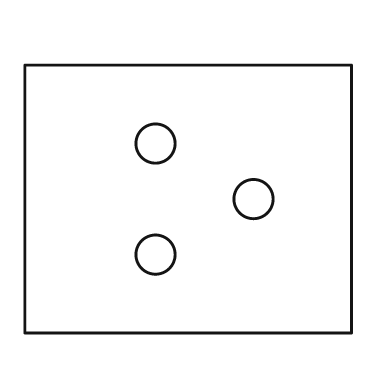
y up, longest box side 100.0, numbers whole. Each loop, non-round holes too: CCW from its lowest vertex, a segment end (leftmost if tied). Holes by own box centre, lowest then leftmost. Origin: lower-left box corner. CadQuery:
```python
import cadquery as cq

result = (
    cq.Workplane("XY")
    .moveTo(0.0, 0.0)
    .lineTo(100.0, 0.0)
    .lineTo(100.0, 82.0)
    .lineTo(0.0, 82.0)
    .close()
    .moveTo(40.0, 24.0)
    .circle(6.0)
    .moveTo(70.0, 41.0)
    .circle(6.0)
    .moveTo(40.0, 58.0)
    .circle(6.0)
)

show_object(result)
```